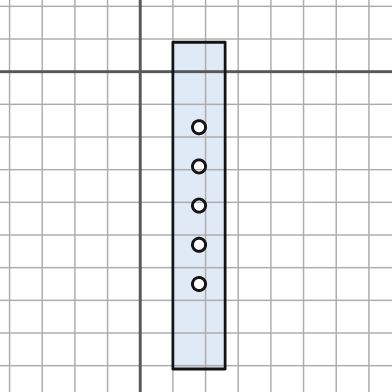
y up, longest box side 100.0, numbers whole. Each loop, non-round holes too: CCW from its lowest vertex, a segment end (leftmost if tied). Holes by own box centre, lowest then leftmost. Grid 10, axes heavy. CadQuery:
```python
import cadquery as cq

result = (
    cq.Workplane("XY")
    .moveTo(10.0, -91.0)
    .lineTo(26.0, -91.0)
    .lineTo(26.0, 9.0)
    .lineTo(10.0, 9.0)
    .close()
    .moveTo(18.0, -65.0)
    .circle(2.0)
    .moveTo(18.0, -53.0)
    .circle(2.0)
    .moveTo(18.0, -41.0)
    .circle(2.0)
    .moveTo(18.0, -29.0)
    .circle(2.0)
    .moveTo(18.0, -17.0)
    .circle(2.0)
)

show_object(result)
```